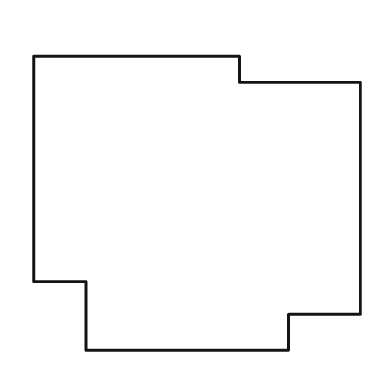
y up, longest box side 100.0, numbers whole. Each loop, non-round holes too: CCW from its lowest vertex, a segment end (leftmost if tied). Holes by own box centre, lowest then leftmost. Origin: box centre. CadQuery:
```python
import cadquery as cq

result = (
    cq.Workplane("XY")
    .moveTo(-34.0, -45.0)
    .lineTo(28.0, -45.0)
    .lineTo(28.0, -34.0)
    .lineTo(50.0, -34.0)
    .lineTo(50.0, 37.0)
    .lineTo(13.0, 37.0)
    .lineTo(13.0, 45.0)
    .lineTo(-50.0, 45.0)
    .lineTo(-50.0, -24.0)
    .lineTo(-34.0, -24.0)
    .close()
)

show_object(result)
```